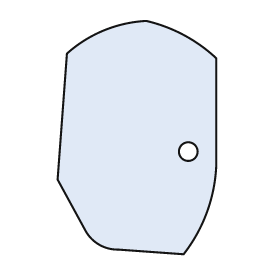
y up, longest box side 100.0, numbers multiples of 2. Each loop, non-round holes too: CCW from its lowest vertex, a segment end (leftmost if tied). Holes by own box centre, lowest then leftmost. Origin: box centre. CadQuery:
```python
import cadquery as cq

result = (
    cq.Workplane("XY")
    .moveTo(20.0, -50.0)
    .threePointArc((30.0, -32.0), (34.0, -12.0))
    .lineTo(34.0, 34.0)
    .threePointArc((20.0, 44.0), (4.0, 50.0))
    .threePointArc((-14.0, 46.0), (-30.0, 36.0))
    .lineTo(-34.0, -18.0)
    .lineTo(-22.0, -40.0)
    .threePointArc((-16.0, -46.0), (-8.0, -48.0))
    .close()
    .moveTo(22.0, -6.0)
    .circle(4.0)
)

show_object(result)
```